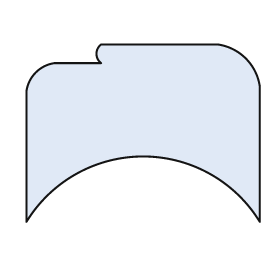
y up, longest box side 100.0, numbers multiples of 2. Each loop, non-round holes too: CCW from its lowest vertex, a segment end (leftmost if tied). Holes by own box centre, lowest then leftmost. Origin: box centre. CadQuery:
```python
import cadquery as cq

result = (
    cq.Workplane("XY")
    .moveTo(-50.0, -38.0)
    .threePointArc((0.0, -10.0), (50.0, -38.0))
    .lineTo(50.0, 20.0)
    .threePointArc((44.0, 32.0), (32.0, 38.0))
    .lineTo(-18.0, 38.0)
    .threePointArc((-20.0, 34.0), (-18.0, 30.0))
    .lineTo(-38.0, 30.0)
    .threePointArc((-46.0, 26.0), (-50.0, 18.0))
    .close()
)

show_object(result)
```